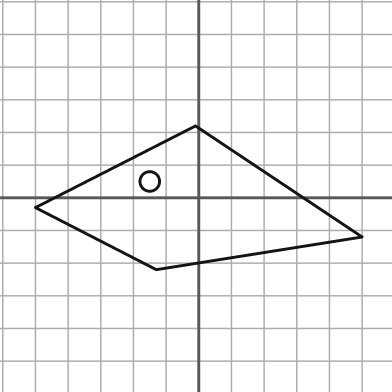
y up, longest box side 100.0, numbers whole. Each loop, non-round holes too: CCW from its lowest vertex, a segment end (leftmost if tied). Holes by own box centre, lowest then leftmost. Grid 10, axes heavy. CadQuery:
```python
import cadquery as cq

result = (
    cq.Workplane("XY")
    .moveTo(-13.0, -22.0)
    .lineTo(50.0, -12.0)
    .lineTo(-1.0, 22.0)
    .lineTo(-50.0, -3.0)
    .close()
    .moveTo(-15.0, 5.0)
    .circle(3.0)
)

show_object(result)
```